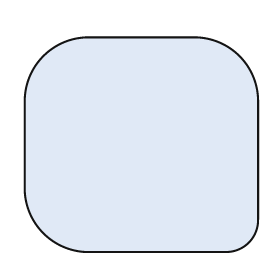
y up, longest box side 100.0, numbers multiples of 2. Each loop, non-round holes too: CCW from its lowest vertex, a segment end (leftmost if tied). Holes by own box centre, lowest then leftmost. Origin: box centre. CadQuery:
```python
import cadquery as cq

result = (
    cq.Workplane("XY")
    .moveTo(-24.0, -46.0)
    .lineTo(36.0, -46.0)
    .threePointArc((46.0, -42.0), (50.0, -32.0))
    .lineTo(50.0, 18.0)
    .threePointArc((42.0, 38.0), (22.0, 46.0))
    .lineTo(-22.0, 46.0)
    .threePointArc((-42.0, 38.0), (-50.0, 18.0))
    .lineTo(-50.0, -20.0)
    .threePointArc((-42.0, -38.0), (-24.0, -46.0))
    .close()
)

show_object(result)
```